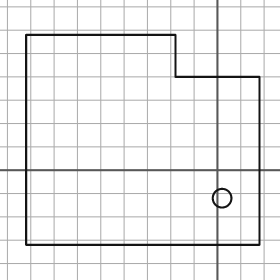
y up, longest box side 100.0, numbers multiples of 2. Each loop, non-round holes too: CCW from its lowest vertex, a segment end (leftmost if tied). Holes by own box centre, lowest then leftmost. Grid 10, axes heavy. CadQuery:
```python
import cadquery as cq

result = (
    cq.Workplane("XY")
    .moveTo(-82.0, -32.0)
    .lineTo(18.0, -32.0)
    .lineTo(18.0, 40.0)
    .lineTo(-18.0, 40.0)
    .lineTo(-18.0, 58.0)
    .lineTo(-82.0, 58.0)
    .close()
    .moveTo(2.0, -12.0)
    .circle(4.0)
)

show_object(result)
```